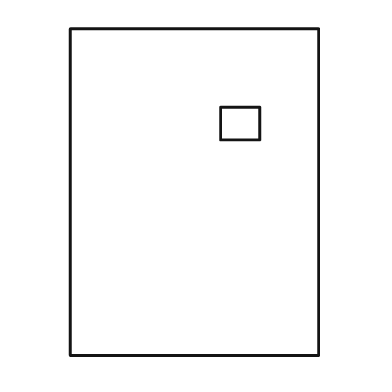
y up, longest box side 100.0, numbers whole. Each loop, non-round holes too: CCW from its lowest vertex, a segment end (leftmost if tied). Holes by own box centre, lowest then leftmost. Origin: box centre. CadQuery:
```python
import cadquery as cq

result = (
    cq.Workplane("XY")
    .moveTo(-38.0, -50.0)
    .lineTo(38.0, -50.0)
    .lineTo(38.0, 50.0)
    .lineTo(-38.0, 50.0)
    .close()
    .moveTo(8.0, 16.0)
    .lineTo(20.0, 16.0)
    .lineTo(20.0, 26.0)
    .lineTo(8.0, 26.0)
    .close()
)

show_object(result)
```